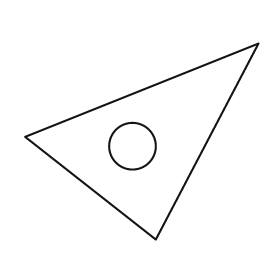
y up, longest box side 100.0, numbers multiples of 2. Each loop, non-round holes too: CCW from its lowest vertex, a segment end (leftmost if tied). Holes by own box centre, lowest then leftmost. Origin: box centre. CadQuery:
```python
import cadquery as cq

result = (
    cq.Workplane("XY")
    .moveTo(6.0, -42.0)
    .lineTo(50.0, 42.0)
    .lineTo(-50.0, 2.0)
    .close()
    .moveTo(-4.0, -2.0)
    .circle(10.0)
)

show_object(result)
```